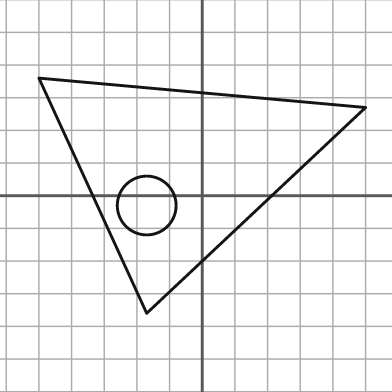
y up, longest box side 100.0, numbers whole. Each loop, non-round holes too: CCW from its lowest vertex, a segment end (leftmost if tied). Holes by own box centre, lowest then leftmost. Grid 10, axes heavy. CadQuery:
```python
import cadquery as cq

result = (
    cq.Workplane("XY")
    .moveTo(-17.0, -36.0)
    .lineTo(50.0, 27.0)
    .lineTo(-50.0, 36.0)
    .close()
    .moveTo(-17.0, -3.0)
    .circle(9.0)
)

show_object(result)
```